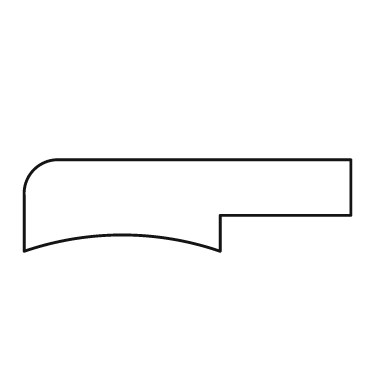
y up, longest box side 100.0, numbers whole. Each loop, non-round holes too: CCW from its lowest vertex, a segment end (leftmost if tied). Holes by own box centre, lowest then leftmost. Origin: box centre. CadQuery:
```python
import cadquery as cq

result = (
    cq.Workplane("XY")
    .moveTo(-50.0, -14.0)
    .threePointArc((-20.0, -9.0), (10.0, -14.0))
    .lineTo(10.0, -3.0)
    .lineTo(50.0, -3.0)
    .lineTo(50.0, 14.0)
    .lineTo(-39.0, 14.0)
    .threePointArc((-47.0, 11.0), (-50.0, 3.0))
    .close()
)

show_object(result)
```